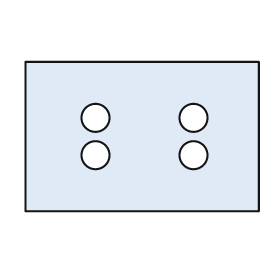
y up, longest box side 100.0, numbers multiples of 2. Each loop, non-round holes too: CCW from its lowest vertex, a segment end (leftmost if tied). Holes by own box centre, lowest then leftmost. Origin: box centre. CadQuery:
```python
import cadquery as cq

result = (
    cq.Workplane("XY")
    .moveTo(-50.0, -32.0)
    .lineTo(50.0, -32.0)
    .lineTo(50.0, 32.0)
    .lineTo(-50.0, 32.0)
    .close()
    .moveTo(-20.0, -8.0)
    .circle(6.0)
    .moveTo(22.0, -8.0)
    .circle(6.0)
    .moveTo(-20.0, 8.0)
    .circle(6.0)
    .moveTo(22.0, 8.0)
    .circle(6.0)
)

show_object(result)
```